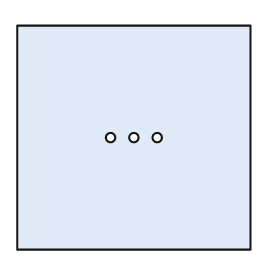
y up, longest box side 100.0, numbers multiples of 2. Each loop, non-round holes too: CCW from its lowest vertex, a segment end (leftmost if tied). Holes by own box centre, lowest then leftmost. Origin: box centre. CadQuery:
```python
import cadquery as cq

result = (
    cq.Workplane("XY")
    .moveTo(-50.0, -48.0)
    .lineTo(50.0, -48.0)
    .lineTo(50.0, 48.0)
    .lineTo(-50.0, 48.0)
    .close()
    .moveTo(-10.0, 0.0)
    .circle(2.0)
    .moveTo(0.0, 0.0)
    .circle(2.0)
    .moveTo(10.0, 0.0)
    .circle(2.0)
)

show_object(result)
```